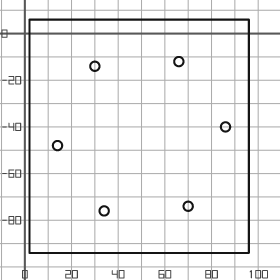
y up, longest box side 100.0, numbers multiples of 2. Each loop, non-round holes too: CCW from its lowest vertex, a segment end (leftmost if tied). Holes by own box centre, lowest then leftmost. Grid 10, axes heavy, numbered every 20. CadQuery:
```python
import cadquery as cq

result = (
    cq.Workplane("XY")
    .moveTo(2.0, -94.0)
    .lineTo(96.0, -94.0)
    .lineTo(96.0, 6.0)
    .lineTo(2.0, 6.0)
    .close()
    .moveTo(34.0, -76.0)
    .circle(2.0)
    .moveTo(70.0, -74.0)
    .circle(2.0)
    .moveTo(14.0, -48.0)
    .circle(2.0)
    .moveTo(86.0, -40.0)
    .circle(2.0)
    .moveTo(30.0, -14.0)
    .circle(2.0)
    .moveTo(66.0, -12.0)
    .circle(2.0)
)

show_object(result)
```